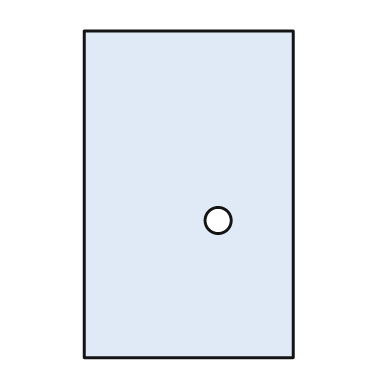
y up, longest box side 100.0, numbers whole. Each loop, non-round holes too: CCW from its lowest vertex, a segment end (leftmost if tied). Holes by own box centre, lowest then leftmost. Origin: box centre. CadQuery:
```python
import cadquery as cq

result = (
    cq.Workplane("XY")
    .moveTo(-32.0, -50.0)
    .lineTo(32.0, -50.0)
    .lineTo(32.0, 50.0)
    .lineTo(-32.0, 50.0)
    .close()
    .moveTo(9.0, -8.0)
    .circle(4.0)
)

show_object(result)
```